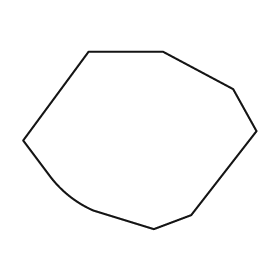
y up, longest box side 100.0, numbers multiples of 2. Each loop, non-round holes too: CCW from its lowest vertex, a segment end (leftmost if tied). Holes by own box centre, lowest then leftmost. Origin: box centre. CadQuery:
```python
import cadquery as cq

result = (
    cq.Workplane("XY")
    .moveTo(6.0, -38.0)
    .lineTo(22.0, -32.0)
    .lineTo(50.0, 4.0)
    .lineTo(40.0, 22.0)
    .lineTo(10.0, 38.0)
    .lineTo(-22.0, 38.0)
    .lineTo(-50.0, 0.0)
    .lineTo(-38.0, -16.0)
    .threePointArc((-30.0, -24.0), (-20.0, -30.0))
    .close()
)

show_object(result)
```